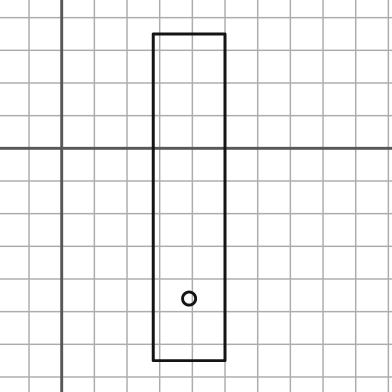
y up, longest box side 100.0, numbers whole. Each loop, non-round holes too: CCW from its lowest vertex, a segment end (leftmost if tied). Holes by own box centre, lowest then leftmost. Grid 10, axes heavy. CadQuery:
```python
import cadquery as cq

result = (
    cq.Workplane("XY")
    .moveTo(28.0, -65.0)
    .lineTo(50.0, -65.0)
    .lineTo(50.0, 35.0)
    .lineTo(28.0, 35.0)
    .close()
    .moveTo(39.0, -46.0)
    .circle(2.0)
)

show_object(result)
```